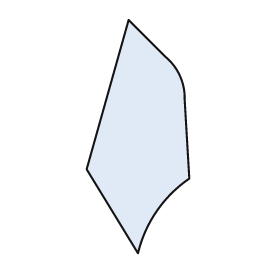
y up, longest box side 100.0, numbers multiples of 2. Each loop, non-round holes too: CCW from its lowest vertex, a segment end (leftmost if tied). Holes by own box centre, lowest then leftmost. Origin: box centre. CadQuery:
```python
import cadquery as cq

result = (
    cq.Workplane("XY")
    .moveTo(0.0, -50.0)
    .threePointArc((8.0, -32.0), (22.0, -18.0))
    .lineTo(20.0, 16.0)
    .threePointArc((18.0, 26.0), (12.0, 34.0))
    .lineTo(-4.0, 50.0)
    .lineTo(-22.0, -14.0)
    .close()
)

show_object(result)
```